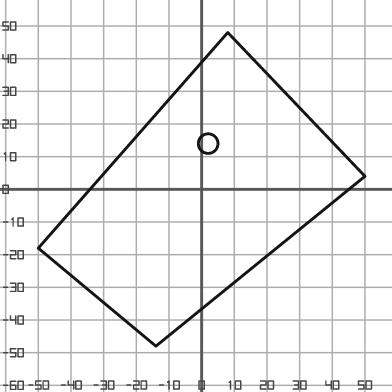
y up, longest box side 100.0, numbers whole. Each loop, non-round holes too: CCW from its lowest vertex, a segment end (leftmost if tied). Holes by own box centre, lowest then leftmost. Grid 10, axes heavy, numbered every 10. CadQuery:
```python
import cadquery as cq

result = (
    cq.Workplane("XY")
    .moveTo(-14.0, -48.0)
    .lineTo(50.0, 4.0)
    .lineTo(8.0, 48.0)
    .lineTo(-50.0, -18.0)
    .close()
    .moveTo(2.0, 14.0)
    .circle(3.0)
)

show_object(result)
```